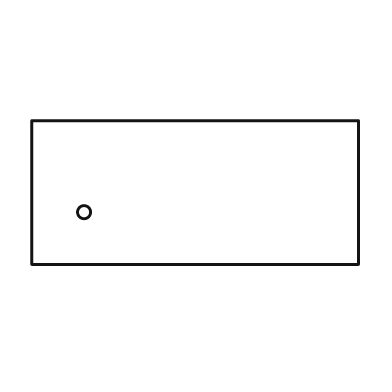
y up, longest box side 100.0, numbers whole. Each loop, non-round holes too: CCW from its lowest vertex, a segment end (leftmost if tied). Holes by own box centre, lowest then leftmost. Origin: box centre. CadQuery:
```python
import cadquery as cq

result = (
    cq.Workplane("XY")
    .moveTo(-50.0, -22.0)
    .lineTo(50.0, -22.0)
    .lineTo(50.0, 22.0)
    .lineTo(-50.0, 22.0)
    .close()
    .moveTo(-34.0, -6.0)
    .circle(2.0)
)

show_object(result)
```